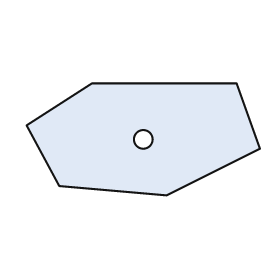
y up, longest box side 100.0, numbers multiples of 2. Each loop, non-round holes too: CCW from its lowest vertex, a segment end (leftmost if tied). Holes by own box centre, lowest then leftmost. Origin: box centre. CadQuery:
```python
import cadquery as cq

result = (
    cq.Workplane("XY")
    .moveTo(10.0, -24.0)
    .lineTo(50.0, -4.0)
    .lineTo(40.0, 24.0)
    .lineTo(-22.0, 24.0)
    .lineTo(-50.0, 6.0)
    .lineTo(-36.0, -20.0)
    .close()
    .moveTo(0.0, 0.0)
    .circle(4.0)
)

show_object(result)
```